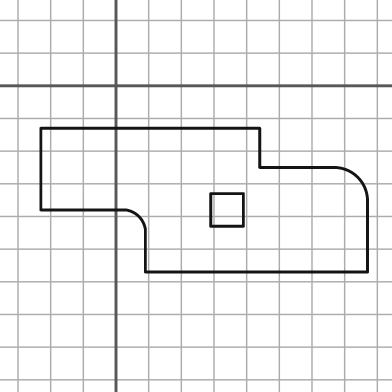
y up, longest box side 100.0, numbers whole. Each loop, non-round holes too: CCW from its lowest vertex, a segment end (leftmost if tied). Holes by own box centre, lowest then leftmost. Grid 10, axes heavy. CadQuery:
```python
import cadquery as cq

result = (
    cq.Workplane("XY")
    .moveTo(9.0, -57.0)
    .lineTo(77.0, -57.0)
    .lineTo(77.0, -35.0)
    .threePointArc((74.0, -28.0), (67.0, -25.0))
    .lineTo(44.0, -25.0)
    .lineTo(44.0, -13.0)
    .lineTo(-23.0, -13.0)
    .lineTo(-23.0, -38.0)
    .lineTo(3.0, -38.0)
    .threePointArc((7.0, -40.0), (9.0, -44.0))
    .close()
    .moveTo(29.0, -43.0)
    .lineTo(39.0, -43.0)
    .lineTo(39.0, -33.0)
    .lineTo(29.0, -33.0)
    .close()
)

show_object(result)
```